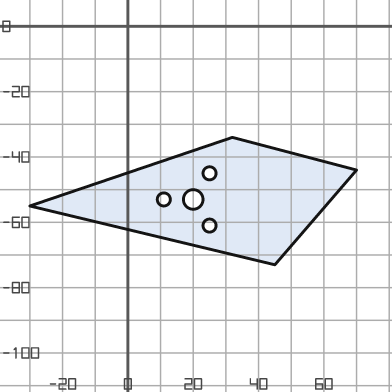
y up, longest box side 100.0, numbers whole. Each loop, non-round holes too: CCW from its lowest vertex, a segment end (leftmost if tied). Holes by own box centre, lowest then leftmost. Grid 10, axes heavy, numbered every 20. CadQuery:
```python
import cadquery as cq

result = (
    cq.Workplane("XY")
    .moveTo(45.0, -73.0)
    .lineTo(70.0, -44.0)
    .lineTo(32.0, -34.0)
    .lineTo(-30.0, -55.0)
    .close()
    .moveTo(25.0, -61.0)
    .circle(2.0)
    .moveTo(11.0, -53.0)
    .circle(2.0)
    .moveTo(20.0, -53.0)
    .circle(3.0)
    .moveTo(25.0, -45.0)
    .circle(2.0)
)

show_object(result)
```